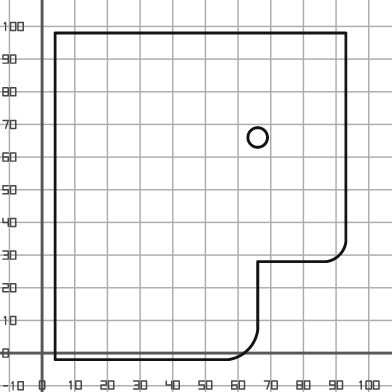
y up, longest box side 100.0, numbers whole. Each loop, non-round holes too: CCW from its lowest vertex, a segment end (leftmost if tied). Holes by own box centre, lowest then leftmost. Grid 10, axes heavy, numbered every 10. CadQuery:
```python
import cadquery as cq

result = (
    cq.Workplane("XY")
    .moveTo(4.0, -2.0)
    .lineTo(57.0, -2.0)
    .threePointArc((63.0, 1.0), (66.0, 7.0))
    .lineTo(66.0, 28.0)
    .lineTo(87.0, 28.0)
    .threePointArc((91.0, 30.0), (93.0, 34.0))
    .lineTo(93.0, 98.0)
    .lineTo(4.0, 98.0)
    .close()
    .moveTo(66.0, 66.0)
    .circle(3.0)
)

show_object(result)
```